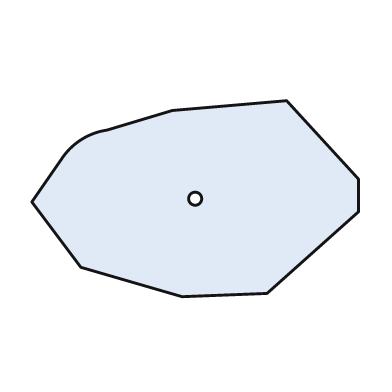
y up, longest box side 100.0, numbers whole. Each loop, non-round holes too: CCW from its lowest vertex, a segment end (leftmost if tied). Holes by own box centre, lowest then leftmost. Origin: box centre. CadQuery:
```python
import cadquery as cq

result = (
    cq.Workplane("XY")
    .moveTo(-4.0, -30.0)
    .lineTo(22.0, -29.0)
    .lineTo(50.0, -4.0)
    .lineTo(50.0, 6.0)
    .lineTo(28.0, 30.0)
    .lineTo(-7.0, 27.0)
    .lineTo(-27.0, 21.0)
    .threePointArc((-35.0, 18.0), (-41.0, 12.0))
    .lineTo(-50.0, -1.0)
    .lineTo(-35.0, -21.0)
    .close()
    .moveTo(0.0, 0.0)
    .circle(2.0)
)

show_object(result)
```